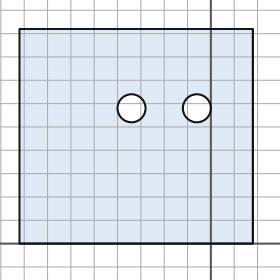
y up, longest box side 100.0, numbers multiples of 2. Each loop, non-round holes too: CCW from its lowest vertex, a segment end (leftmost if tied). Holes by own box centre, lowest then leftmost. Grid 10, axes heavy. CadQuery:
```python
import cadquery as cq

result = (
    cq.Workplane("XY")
    .moveTo(-82.0, 0.0)
    .lineTo(18.0, 0.0)
    .lineTo(18.0, 92.0)
    .lineTo(-82.0, 92.0)
    .close()
    .moveTo(-34.0, 58.0)
    .circle(6.0)
    .moveTo(-6.0, 58.0)
    .circle(6.0)
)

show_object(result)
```